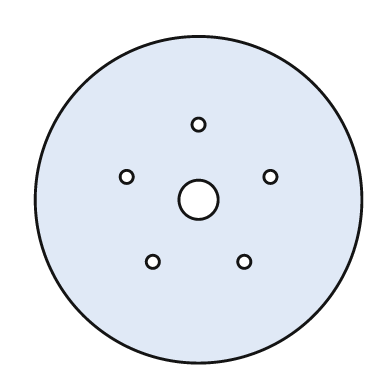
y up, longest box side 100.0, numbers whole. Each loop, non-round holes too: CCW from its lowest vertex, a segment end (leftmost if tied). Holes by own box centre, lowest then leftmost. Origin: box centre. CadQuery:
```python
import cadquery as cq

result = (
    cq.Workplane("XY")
    .moveTo(0.0, 0.0)
    .circle(50.0)
    .moveTo(-14.0, -19.0)
    .circle(2.0)
    .moveTo(14.0, -19.0)
    .circle(2.0)
    .moveTo(0.0, 0.0)
    .circle(6.0)
    .moveTo(-22.0, 7.0)
    .circle(2.0)
    .moveTo(22.0, 7.0)
    .circle(2.0)
    .moveTo(0.0, 23.0)
    .circle(2.0)
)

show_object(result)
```